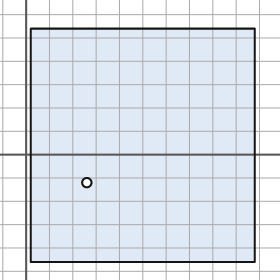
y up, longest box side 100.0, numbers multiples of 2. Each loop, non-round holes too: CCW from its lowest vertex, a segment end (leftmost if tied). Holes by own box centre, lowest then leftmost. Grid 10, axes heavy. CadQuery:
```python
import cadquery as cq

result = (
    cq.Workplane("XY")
    .moveTo(2.0, -46.0)
    .lineTo(98.0, -46.0)
    .lineTo(98.0, 54.0)
    .lineTo(2.0, 54.0)
    .close()
    .moveTo(26.0, -12.0)
    .circle(2.0)
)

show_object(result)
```